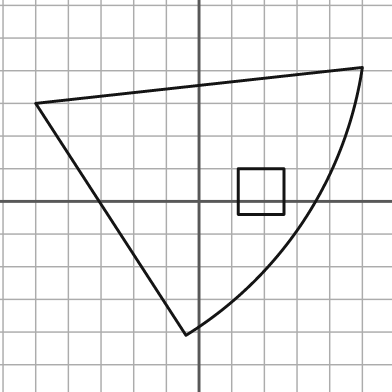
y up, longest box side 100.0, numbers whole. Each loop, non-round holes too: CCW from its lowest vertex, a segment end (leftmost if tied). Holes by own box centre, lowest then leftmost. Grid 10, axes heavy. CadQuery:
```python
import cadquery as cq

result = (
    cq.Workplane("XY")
    .moveTo(-4.0, -41.0)
    .threePointArc((32.0, -6.0), (50.0, 41.0))
    .lineTo(-50.0, 30.0)
    .close()
    .moveTo(12.0, -4.0)
    .lineTo(26.0, -4.0)
    .lineTo(26.0, 10.0)
    .lineTo(12.0, 10.0)
    .close()
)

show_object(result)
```